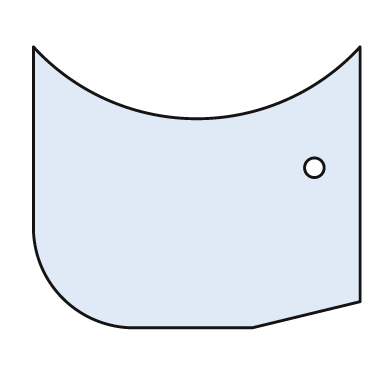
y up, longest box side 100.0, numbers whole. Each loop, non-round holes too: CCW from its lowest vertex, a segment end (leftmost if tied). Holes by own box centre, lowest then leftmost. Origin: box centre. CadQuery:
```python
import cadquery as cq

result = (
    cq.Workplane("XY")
    .moveTo(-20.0, -43.0)
    .lineTo(17.0, -43.0)
    .lineTo(50.0, -35.0)
    .lineTo(50.0, 43.0)
    .threePointArc((0.0, 21.0), (-50.0, 43.0))
    .lineTo(-50.0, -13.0)
    .threePointArc((-41.0, -34.0), (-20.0, -43.0))
    .close()
    .moveTo(36.0, 6.0)
    .circle(3.0)
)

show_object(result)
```